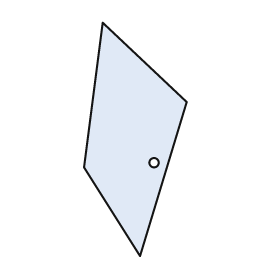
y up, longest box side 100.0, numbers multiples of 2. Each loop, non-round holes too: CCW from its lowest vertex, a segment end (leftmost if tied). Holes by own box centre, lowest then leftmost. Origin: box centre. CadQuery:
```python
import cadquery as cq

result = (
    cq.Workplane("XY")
    .moveTo(2.0, -50.0)
    .lineTo(22.0, 16.0)
    .lineTo(-14.0, 50.0)
    .lineTo(-22.0, -12.0)
    .close()
    .moveTo(8.0, -10.0)
    .circle(2.0)
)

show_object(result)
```